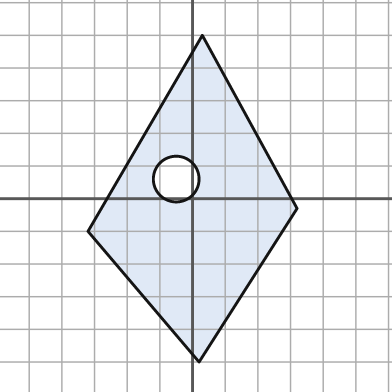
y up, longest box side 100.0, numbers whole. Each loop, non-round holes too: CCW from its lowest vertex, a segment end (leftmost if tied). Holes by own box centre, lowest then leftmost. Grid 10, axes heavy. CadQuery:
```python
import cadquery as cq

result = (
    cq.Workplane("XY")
    .moveTo(2.0, -50.0)
    .lineTo(32.0, -3.0)
    .lineTo(3.0, 50.0)
    .lineTo(-32.0, -10.0)
    .close()
    .moveTo(-5.0, 6.0)
    .circle(7.0)
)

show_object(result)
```